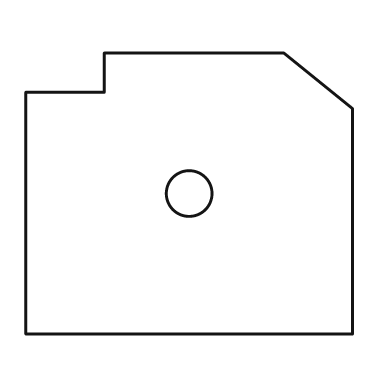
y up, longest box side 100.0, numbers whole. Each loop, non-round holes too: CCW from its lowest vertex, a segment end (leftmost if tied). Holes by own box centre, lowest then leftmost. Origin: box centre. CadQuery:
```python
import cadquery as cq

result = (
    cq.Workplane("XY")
    .moveTo(-50.0, -43.0)
    .lineTo(50.0, -43.0)
    .lineTo(50.0, 26.0)
    .lineTo(29.0, 43.0)
    .lineTo(-26.0, 43.0)
    .lineTo(-26.0, 31.0)
    .lineTo(-50.0, 31.0)
    .close()
    .moveTo(0.0, 0.0)
    .circle(7.0)
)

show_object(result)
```